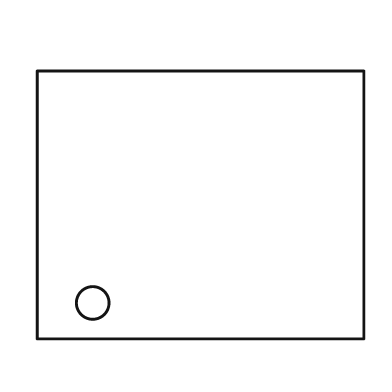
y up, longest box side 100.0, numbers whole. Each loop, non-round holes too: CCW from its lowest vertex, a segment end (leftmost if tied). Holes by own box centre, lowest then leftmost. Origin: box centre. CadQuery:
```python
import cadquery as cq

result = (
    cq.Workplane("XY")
    .moveTo(-50.0, -41.0)
    .lineTo(50.0, -41.0)
    .lineTo(50.0, 41.0)
    .lineTo(-50.0, 41.0)
    .close()
    .moveTo(-33.0, -30.0)
    .circle(5.0)
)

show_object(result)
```